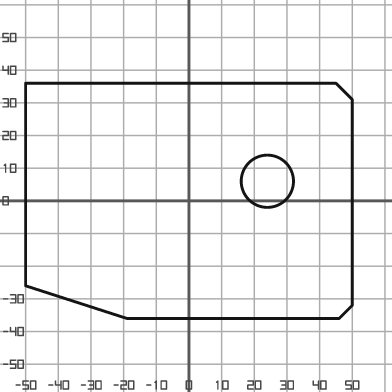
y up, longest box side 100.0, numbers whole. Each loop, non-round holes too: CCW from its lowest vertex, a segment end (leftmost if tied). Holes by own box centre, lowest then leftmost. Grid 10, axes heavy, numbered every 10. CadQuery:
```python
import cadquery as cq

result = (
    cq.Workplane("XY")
    .moveTo(-19.0, -36.0)
    .lineTo(46.0, -36.0)
    .lineTo(50.0, -32.0)
    .lineTo(50.0, 31.0)
    .lineTo(45.0, 36.0)
    .lineTo(-50.0, 36.0)
    .lineTo(-50.0, -26.0)
    .close()
    .moveTo(24.0, 6.0)
    .circle(8.0)
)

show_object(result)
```